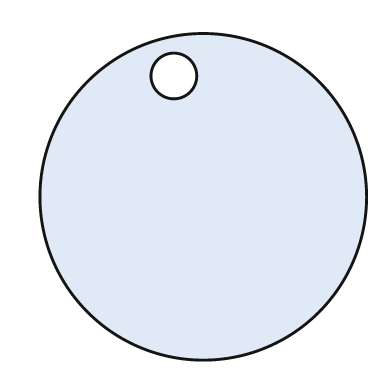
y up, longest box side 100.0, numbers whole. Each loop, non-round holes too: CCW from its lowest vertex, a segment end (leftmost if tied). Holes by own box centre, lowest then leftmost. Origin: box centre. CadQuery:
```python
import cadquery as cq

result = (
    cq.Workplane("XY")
    .moveTo(0.0, 0.0)
    .circle(50.0)
    .moveTo(-9.0, 37.0)
    .circle(7.0)
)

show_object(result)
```